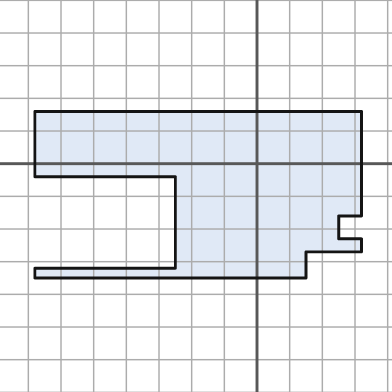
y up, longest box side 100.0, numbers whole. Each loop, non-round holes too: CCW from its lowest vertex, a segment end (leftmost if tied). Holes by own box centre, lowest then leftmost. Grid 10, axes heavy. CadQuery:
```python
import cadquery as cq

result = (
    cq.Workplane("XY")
    .moveTo(-68.0, -35.0)
    .lineTo(15.0, -35.0)
    .lineTo(15.0, -27.0)
    .lineTo(32.0, -27.0)
    .lineTo(32.0, -23.0)
    .lineTo(25.0, -23.0)
    .lineTo(25.0, -16.0)
    .lineTo(32.0, -16.0)
    .lineTo(32.0, 16.0)
    .lineTo(-68.0, 16.0)
    .lineTo(-68.0, -4.0)
    .lineTo(-25.0, -4.0)
    .lineTo(-25.0, -32.0)
    .lineTo(-68.0, -32.0)
    .close()
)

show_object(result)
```